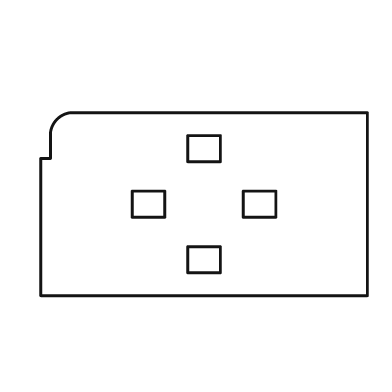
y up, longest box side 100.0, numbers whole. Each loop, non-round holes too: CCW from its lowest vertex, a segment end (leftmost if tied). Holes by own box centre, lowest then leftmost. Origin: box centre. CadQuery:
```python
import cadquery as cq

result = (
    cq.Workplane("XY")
    .moveTo(-50.0, -28.0)
    .lineTo(50.0, -28.0)
    .lineTo(50.0, 28.0)
    .lineTo(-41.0, 28.0)
    .threePointArc((-45.0, 26.0), (-47.0, 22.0))
    .lineTo(-47.0, 14.0)
    .lineTo(-50.0, 14.0)
    .close()
    .moveTo(-5.0, -21.0)
    .lineTo(5.0, -21.0)
    .lineTo(5.0, -13.0)
    .lineTo(-5.0, -13.0)
    .close()
    .moveTo(-22.0, -4.0)
    .lineTo(-12.0, -4.0)
    .lineTo(-12.0, 4.0)
    .lineTo(-22.0, 4.0)
    .close()
    .moveTo(12.0, -4.0)
    .lineTo(22.0, -4.0)
    .lineTo(22.0, 4.0)
    .lineTo(12.0, 4.0)
    .close()
    .moveTo(-5.0, 13.0)
    .lineTo(5.0, 13.0)
    .lineTo(5.0, 21.0)
    .lineTo(-5.0, 21.0)
    .close()
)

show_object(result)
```